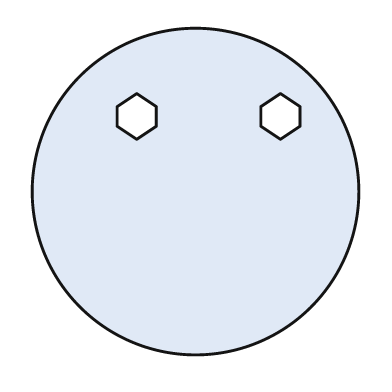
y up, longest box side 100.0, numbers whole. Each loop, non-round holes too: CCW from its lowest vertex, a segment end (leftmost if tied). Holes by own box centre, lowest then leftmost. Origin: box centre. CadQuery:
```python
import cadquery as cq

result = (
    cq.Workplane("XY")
    .moveTo(0.0, 0.0)
    .circle(50.0)
    .moveTo(-18.0, 16.0)
    .lineTo(-12.0, 20.0)
    .lineTo(-12.0, 26.0)
    .lineTo(-18.0, 30.0)
    .lineTo(-24.0, 26.0)
    .lineTo(-24.0, 20.0)
    .close()
    .moveTo(26.0, 16.0)
    .lineTo(32.0, 20.0)
    .lineTo(32.0, 26.0)
    .lineTo(26.0, 30.0)
    .lineTo(20.0, 26.0)
    .lineTo(20.0, 20.0)
    .close()
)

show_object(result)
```